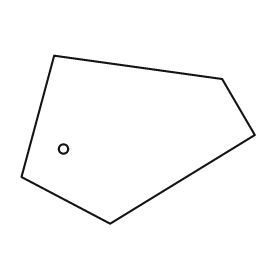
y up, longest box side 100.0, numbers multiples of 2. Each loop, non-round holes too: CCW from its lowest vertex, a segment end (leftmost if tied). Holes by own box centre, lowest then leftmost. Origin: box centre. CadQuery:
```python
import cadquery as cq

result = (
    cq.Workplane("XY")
    .moveTo(-12.0, -36.0)
    .lineTo(50.0, 2.0)
    .lineTo(36.0, 26.0)
    .lineTo(-36.0, 36.0)
    .lineTo(-50.0, -16.0)
    .close()
    .moveTo(-32.0, -4.0)
    .circle(2.0)
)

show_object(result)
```